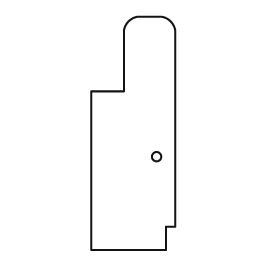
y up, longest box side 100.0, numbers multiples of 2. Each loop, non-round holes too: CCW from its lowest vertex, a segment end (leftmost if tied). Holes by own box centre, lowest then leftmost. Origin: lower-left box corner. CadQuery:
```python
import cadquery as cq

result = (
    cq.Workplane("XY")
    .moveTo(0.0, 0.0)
    .lineTo(32.0, 0.0)
    .lineTo(32.0, 10.0)
    .lineTo(36.0, 10.0)
    .lineTo(36.0, 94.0)
    .threePointArc((34.0, 98.0), (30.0, 100.0))
    .lineTo(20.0, 100.0)
    .threePointArc((16.0, 98.0), (14.0, 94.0))
    .lineTo(14.0, 68.0)
    .lineTo(0.0, 68.0)
    .close()
    .moveTo(28.0, 40.0)
    .circle(2.0)
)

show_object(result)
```